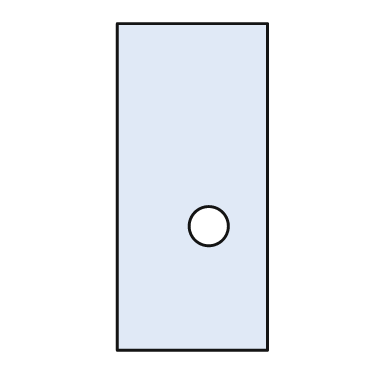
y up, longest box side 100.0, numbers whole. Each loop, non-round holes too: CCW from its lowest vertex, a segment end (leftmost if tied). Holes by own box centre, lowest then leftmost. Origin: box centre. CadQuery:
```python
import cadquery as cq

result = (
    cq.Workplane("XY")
    .moveTo(-23.0, -50.0)
    .lineTo(23.0, -50.0)
    .lineTo(23.0, 50.0)
    .lineTo(-23.0, 50.0)
    .close()
    .moveTo(5.0, -12.0)
    .circle(6.0)
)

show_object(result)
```